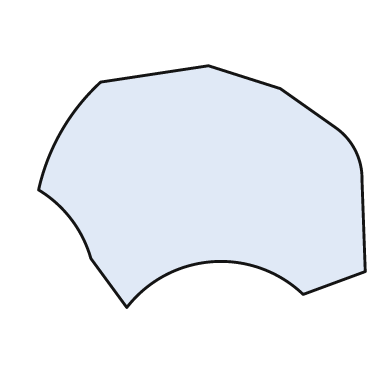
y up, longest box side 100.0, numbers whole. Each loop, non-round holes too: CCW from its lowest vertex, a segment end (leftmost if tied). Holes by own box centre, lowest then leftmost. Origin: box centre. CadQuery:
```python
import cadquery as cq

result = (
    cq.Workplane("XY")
    .moveTo(-23.0, -37.0)
    .threePointArc((3.0, -23.0), (31.0, -33.0))
    .lineTo(50.0, -26.0)
    .lineTo(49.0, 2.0)
    .threePointArc((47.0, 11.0), (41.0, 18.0))
    .lineTo(24.0, 30.0)
    .lineTo(2.0, 37.0)
    .lineTo(-31.0, 32.0)
    .threePointArc((-43.0, 17.0), (-50.0, -1.0))
    .threePointArc((-40.0, -10.0), (-34.0, -22.0))
    .close()
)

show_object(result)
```